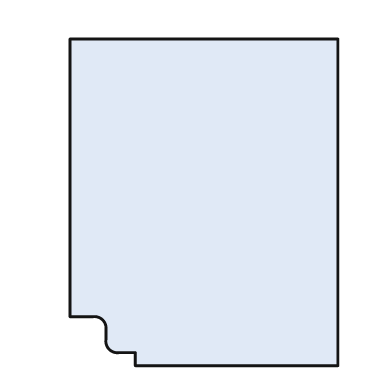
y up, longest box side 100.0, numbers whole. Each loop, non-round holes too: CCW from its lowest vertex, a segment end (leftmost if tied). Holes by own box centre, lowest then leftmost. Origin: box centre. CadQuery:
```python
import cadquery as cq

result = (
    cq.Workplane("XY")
    .moveTo(-21.0, -50.0)
    .lineTo(41.0, -50.0)
    .lineTo(41.0, 50.0)
    .lineTo(-41.0, 50.0)
    .lineTo(-41.0, -35.0)
    .lineTo(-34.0, -35.0)
    .threePointArc((-31.0, -36.0), (-30.0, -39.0))
    .lineTo(-30.0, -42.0)
    .threePointArc((-29.0, -45.0), (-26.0, -46.0))
    .lineTo(-21.0, -46.0)
    .close()
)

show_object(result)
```